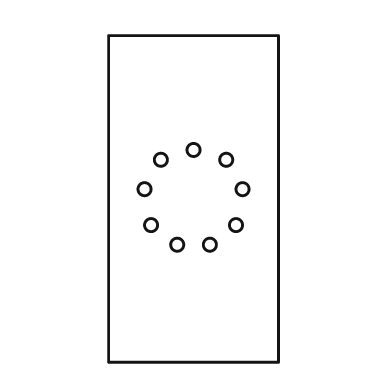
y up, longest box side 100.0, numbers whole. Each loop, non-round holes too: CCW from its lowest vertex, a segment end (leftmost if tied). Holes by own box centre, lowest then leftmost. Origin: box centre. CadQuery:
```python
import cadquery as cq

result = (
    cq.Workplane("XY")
    .moveTo(-26.0, -50.0)
    .lineTo(26.0, -50.0)
    .lineTo(26.0, 50.0)
    .lineTo(-26.0, 50.0)
    .close()
    .moveTo(-5.0, -14.0)
    .circle(2.0)
    .moveTo(5.0, -14.0)
    .circle(2.0)
    .moveTo(-13.0, -8.0)
    .circle(2.0)
    .moveTo(13.0, -8.0)
    .circle(2.0)
    .moveTo(-15.0, 3.0)
    .circle(2.0)
    .moveTo(15.0, 3.0)
    .circle(2.0)
    .moveTo(-10.0, 12.0)
    .circle(2.0)
    .moveTo(10.0, 12.0)
    .circle(2.0)
    .moveTo(0.0, 15.0)
    .circle(2.0)
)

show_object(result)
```